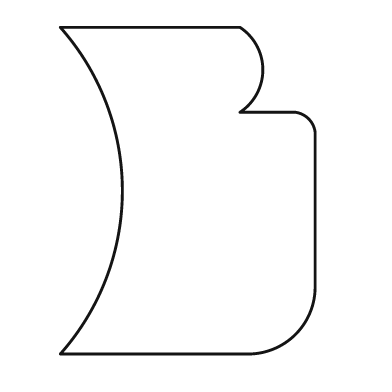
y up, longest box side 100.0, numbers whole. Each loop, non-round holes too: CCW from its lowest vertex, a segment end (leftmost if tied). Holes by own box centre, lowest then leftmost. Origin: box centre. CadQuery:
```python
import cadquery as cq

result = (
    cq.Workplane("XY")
    .moveTo(-39.0, -50.0)
    .lineTo(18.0, -50.0)
    .threePointArc((33.0, -44.0), (39.0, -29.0))
    .lineTo(39.0, 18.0)
    .threePointArc((37.0, 22.0), (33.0, 24.0))
    .lineTo(16.0, 24.0)
    .threePointArc((23.0, 37.0), (16.0, 50.0))
    .lineTo(-39.0, 50.0)
    .threePointArc((-20.0, 0.0), (-39.0, -50.0))
    .close()
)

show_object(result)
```